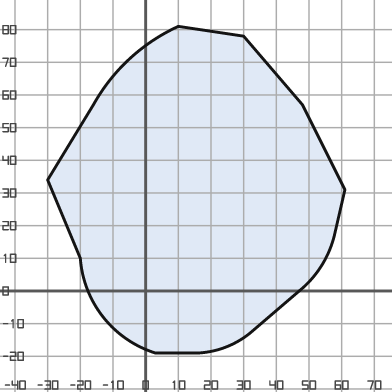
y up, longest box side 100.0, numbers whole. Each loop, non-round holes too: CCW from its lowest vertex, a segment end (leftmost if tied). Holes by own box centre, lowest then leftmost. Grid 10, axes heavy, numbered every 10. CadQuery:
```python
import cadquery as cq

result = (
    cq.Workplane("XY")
    .moveTo(3.0, -19.0)
    .lineTo(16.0, -19.0)
    .threePointArc((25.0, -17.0), (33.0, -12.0))
    .lineTo(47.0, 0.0)
    .threePointArc((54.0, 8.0), (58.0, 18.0))
    .lineTo(61.0, 31.0)
    .lineTo(48.0, 57.0)
    .lineTo(30.0, 78.0)
    .lineTo(10.0, 81.0)
    .threePointArc((-5.0, 71.0), (-16.0, 57.0))
    .lineTo(-30.0, 34.0)
    .lineTo(-20.0, 10.0)
    .threePointArc((-13.0, -8.0), (3.0, -19.0))
    .close()
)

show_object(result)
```